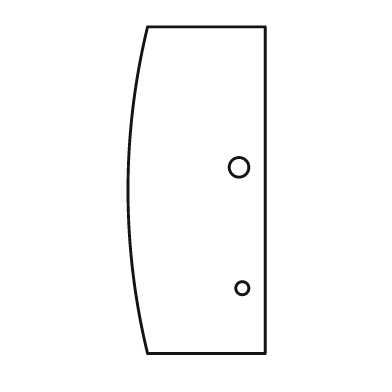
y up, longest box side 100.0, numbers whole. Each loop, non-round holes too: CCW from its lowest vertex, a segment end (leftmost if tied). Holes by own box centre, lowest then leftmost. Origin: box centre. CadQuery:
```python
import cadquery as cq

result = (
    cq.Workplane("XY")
    .moveTo(-15.0, -50.0)
    .lineTo(21.0, -50.0)
    .lineTo(21.0, 50.0)
    .lineTo(-15.0, 50.0)
    .threePointArc((-21.0, 0.0), (-15.0, -50.0))
    .close()
    .moveTo(14.0, -30.0)
    .circle(2.0)
    .moveTo(13.0, 7.0)
    .circle(3.0)
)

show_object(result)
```